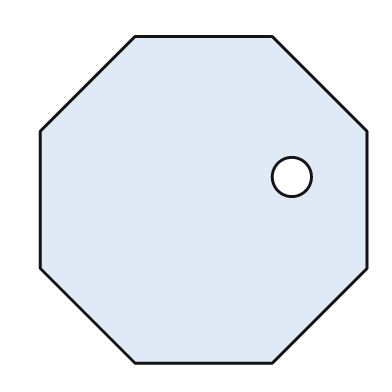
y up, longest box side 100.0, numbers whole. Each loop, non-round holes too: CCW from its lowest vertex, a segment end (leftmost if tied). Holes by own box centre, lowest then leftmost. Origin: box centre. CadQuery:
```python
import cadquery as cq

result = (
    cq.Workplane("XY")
    .moveTo(-21.0, -50.0)
    .lineTo(21.0, -50.0)
    .lineTo(50.0, -21.0)
    .lineTo(50.0, 21.0)
    .lineTo(21.0, 50.0)
    .lineTo(-21.0, 50.0)
    .lineTo(-50.0, 21.0)
    .lineTo(-50.0, -21.0)
    .close()
    .moveTo(27.0, 7.0)
    .circle(6.0)
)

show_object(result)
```